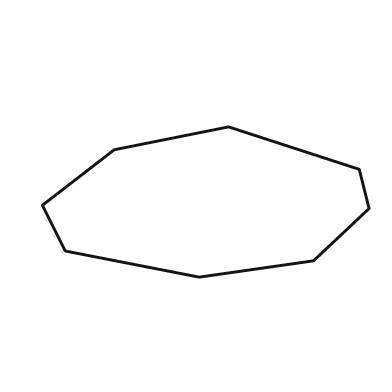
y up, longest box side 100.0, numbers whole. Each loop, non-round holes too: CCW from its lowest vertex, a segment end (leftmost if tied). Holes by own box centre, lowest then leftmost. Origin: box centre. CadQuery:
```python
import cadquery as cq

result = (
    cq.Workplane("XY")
    .moveTo(-2.0, -23.0)
    .lineTo(33.0, -18.0)
    .lineTo(50.0, -2.0)
    .lineTo(47.0, 10.0)
    .lineTo(7.0, 23.0)
    .lineTo(-28.0, 16.0)
    .lineTo(-50.0, -1.0)
    .lineTo(-43.0, -15.0)
    .close()
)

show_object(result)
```